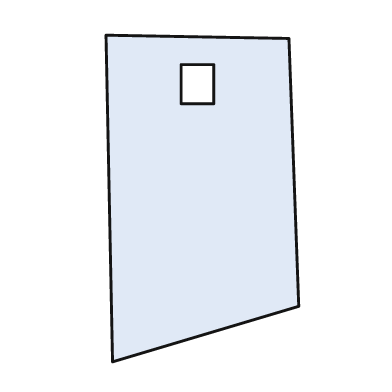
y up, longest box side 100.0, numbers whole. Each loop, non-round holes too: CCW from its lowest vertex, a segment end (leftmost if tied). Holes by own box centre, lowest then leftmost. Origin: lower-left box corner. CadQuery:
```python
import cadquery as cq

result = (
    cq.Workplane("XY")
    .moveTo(2.0, 0.0)
    .lineTo(59.0, 17.0)
    .lineTo(56.0, 99.0)
    .lineTo(0.0, 100.0)
    .close()
    .moveTo(23.0, 79.0)
    .lineTo(33.0, 79.0)
    .lineTo(33.0, 91.0)
    .lineTo(23.0, 91.0)
    .close()
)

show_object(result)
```